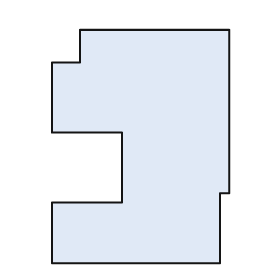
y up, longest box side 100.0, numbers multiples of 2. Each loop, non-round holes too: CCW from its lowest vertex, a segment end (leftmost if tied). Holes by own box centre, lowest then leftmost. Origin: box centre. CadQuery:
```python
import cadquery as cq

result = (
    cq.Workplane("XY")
    .moveTo(-38.0, -50.0)
    .lineTo(34.0, -50.0)
    .lineTo(34.0, -20.0)
    .lineTo(38.0, -20.0)
    .lineTo(38.0, 50.0)
    .lineTo(-26.0, 50.0)
    .lineTo(-26.0, 36.0)
    .lineTo(-38.0, 36.0)
    .lineTo(-38.0, 6.0)
    .lineTo(-8.0, 6.0)
    .lineTo(-8.0, -24.0)
    .lineTo(-38.0, -24.0)
    .close()
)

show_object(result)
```